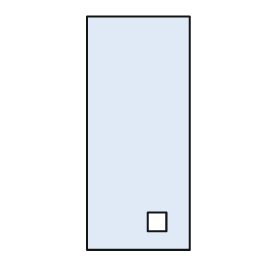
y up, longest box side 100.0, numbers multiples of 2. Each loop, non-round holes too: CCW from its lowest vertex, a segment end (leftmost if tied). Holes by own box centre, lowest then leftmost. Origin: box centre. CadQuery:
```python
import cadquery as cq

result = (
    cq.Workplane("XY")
    .moveTo(-22.0, -50.0)
    .lineTo(22.0, -50.0)
    .lineTo(22.0, 50.0)
    .lineTo(-22.0, 50.0)
    .close()
    .moveTo(4.0, -42.0)
    .lineTo(12.0, -42.0)
    .lineTo(12.0, -34.0)
    .lineTo(4.0, -34.0)
    .close()
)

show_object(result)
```